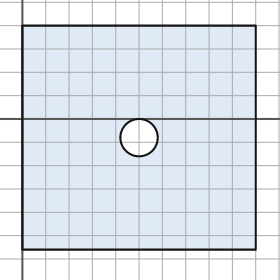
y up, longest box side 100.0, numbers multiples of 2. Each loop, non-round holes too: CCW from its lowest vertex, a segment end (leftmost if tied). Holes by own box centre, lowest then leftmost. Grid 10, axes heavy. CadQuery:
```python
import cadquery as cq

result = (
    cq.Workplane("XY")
    .moveTo(0.0, -56.0)
    .lineTo(100.0, -56.0)
    .lineTo(100.0, 40.0)
    .lineTo(0.0, 40.0)
    .close()
    .moveTo(50.0, -8.0)
    .circle(8.0)
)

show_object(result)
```